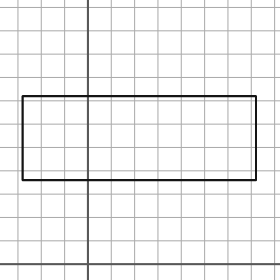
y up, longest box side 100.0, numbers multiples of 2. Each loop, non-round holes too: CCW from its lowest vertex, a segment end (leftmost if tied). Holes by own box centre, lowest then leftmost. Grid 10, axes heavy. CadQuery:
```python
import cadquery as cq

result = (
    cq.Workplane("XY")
    .moveTo(-28.0, 36.0)
    .lineTo(72.0, 36.0)
    .lineTo(72.0, 72.0)
    .lineTo(-28.0, 72.0)
    .close()
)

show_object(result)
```